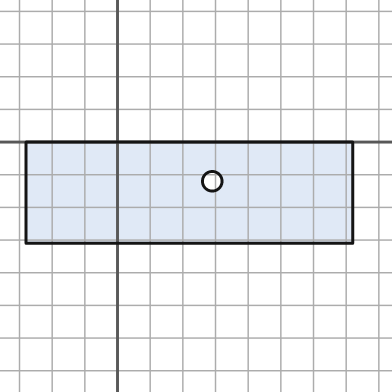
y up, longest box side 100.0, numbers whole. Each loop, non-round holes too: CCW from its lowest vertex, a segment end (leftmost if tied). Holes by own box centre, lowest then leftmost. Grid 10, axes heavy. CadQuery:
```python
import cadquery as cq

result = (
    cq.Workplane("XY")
    .moveTo(-28.0, -31.0)
    .lineTo(72.0, -31.0)
    .lineTo(72.0, 0.0)
    .lineTo(-28.0, 0.0)
    .close()
    .moveTo(29.0, -12.0)
    .circle(3.0)
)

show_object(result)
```